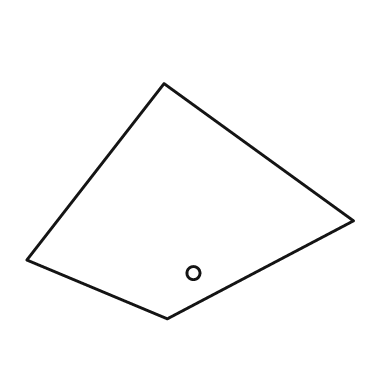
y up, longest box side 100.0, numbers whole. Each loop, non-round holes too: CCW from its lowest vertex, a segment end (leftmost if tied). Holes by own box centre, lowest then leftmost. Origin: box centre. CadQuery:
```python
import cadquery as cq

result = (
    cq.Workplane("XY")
    .moveTo(-7.0, -36.0)
    .lineTo(50.0, -6.0)
    .lineTo(-8.0, 36.0)
    .lineTo(-50.0, -18.0)
    .close()
    .moveTo(1.0, -22.0)
    .circle(2.0)
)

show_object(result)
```